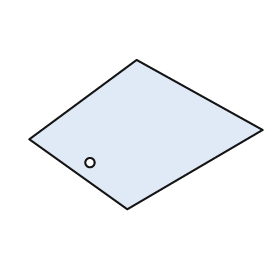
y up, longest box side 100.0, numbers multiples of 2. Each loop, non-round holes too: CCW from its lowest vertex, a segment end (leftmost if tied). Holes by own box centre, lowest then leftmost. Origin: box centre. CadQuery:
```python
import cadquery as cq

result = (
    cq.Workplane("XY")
    .moveTo(-8.0, -32.0)
    .lineTo(50.0, 2.0)
    .lineTo(-4.0, 32.0)
    .lineTo(-50.0, -2.0)
    .close()
    .moveTo(-24.0, -12.0)
    .circle(2.0)
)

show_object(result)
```